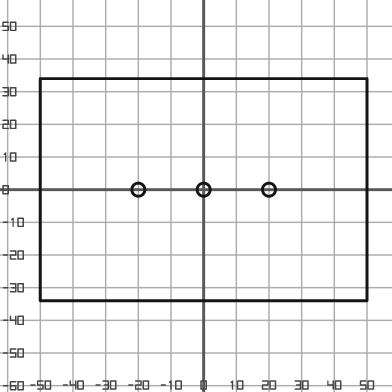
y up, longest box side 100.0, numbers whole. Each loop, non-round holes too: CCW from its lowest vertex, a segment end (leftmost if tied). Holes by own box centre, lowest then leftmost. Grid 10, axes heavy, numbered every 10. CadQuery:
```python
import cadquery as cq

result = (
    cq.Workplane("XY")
    .moveTo(-50.0, -34.0)
    .lineTo(50.0, -34.0)
    .lineTo(50.0, 34.0)
    .lineTo(-50.0, 34.0)
    .close()
    .moveTo(-20.0, 0.0)
    .circle(2.0)
    .moveTo(0.0, 0.0)
    .circle(2.0)
    .moveTo(20.0, 0.0)
    .circle(2.0)
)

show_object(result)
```